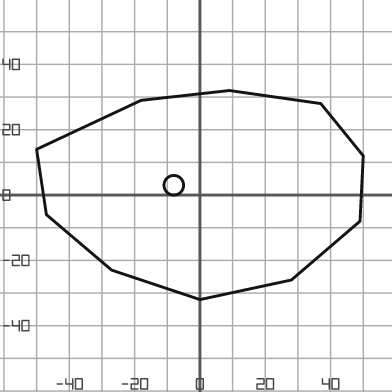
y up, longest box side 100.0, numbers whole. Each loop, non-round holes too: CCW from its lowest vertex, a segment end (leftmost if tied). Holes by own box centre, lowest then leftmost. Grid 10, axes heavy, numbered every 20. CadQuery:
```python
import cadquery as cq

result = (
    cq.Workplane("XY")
    .moveTo(0.0, -32.0)
    .lineTo(28.0, -26.0)
    .lineTo(49.0, -8.0)
    .lineTo(50.0, 12.0)
    .lineTo(37.0, 28.0)
    .lineTo(9.0, 32.0)
    .lineTo(-18.0, 29.0)
    .lineTo(-50.0, 14.0)
    .lineTo(-47.0, -6.0)
    .lineTo(-27.0, -23.0)
    .close()
    .moveTo(-8.0, 3.0)
    .circle(3.0)
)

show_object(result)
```